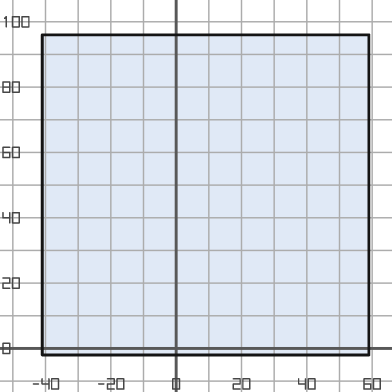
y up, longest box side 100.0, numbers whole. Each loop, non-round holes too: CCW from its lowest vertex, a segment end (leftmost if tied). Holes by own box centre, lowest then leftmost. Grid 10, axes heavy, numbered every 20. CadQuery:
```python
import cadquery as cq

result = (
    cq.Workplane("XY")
    .moveTo(-41.0, -2.0)
    .lineTo(59.0, -2.0)
    .lineTo(59.0, 96.0)
    .lineTo(-41.0, 96.0)
    .close()
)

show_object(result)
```